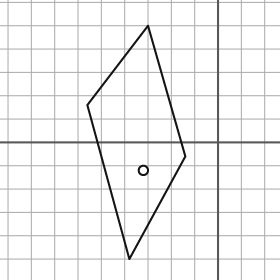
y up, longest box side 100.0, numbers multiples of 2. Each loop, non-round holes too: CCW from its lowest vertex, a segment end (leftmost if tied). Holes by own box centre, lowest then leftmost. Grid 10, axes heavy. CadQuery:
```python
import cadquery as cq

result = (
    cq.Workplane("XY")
    .moveTo(-38.0, -50.0)
    .lineTo(-14.0, -6.0)
    .lineTo(-30.0, 50.0)
    .lineTo(-56.0, 16.0)
    .close()
    .moveTo(-32.0, -12.0)
    .circle(2.0)
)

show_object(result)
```